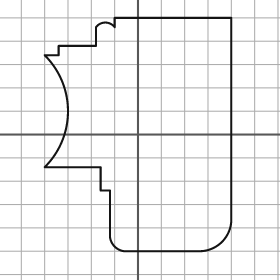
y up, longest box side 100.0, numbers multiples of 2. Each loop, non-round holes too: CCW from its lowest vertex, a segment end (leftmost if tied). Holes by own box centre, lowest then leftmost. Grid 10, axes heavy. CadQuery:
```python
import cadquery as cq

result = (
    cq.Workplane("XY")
    .moveTo(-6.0, -50.0)
    .lineTo(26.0, -50.0)
    .threePointArc((36.0, -46.0), (40.0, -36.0))
    .lineTo(40.0, 50.0)
    .lineTo(-10.0, 50.0)
    .lineTo(-10.0, 46.0)
    .threePointArc((-14.0, 48.0), (-18.0, 46.0))
    .lineTo(-18.0, 38.0)
    .lineTo(-34.0, 38.0)
    .lineTo(-34.0, 34.0)
    .lineTo(-40.0, 34.0)
    .threePointArc((-30.0, 10.0), (-40.0, -14.0))
    .lineTo(-16.0, -14.0)
    .lineTo(-16.0, -24.0)
    .lineTo(-12.0, -24.0)
    .lineTo(-12.0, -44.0)
    .threePointArc((-10.0, -48.0), (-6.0, -50.0))
    .close()
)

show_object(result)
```